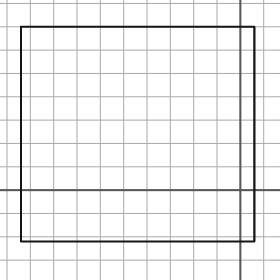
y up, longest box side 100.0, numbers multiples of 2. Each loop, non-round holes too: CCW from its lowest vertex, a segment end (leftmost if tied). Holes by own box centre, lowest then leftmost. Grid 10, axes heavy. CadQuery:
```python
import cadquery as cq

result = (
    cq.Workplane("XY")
    .moveTo(-94.0, -22.0)
    .lineTo(6.0, -22.0)
    .lineTo(6.0, 70.0)
    .lineTo(-94.0, 70.0)
    .close()
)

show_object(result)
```